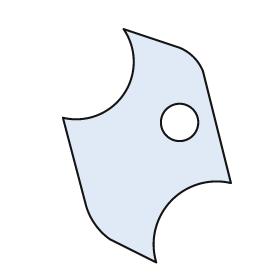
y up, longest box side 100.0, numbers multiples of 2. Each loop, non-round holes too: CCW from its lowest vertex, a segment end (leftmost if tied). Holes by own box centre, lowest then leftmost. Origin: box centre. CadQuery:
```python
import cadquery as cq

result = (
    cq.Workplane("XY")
    .moveTo(4.0, -50.0)
    .threePointArc((10.0, -24.0), (36.0, -16.0))
    .lineTo(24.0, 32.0)
    .threePointArc((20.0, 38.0), (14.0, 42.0))
    .lineTo(-10.0, 50.0)
    .threePointArc((-10.0, 22.0), (-36.0, 12.0))
    .lineTo(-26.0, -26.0)
    .threePointArc((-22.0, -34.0), (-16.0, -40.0))
    .close()
    .moveTo(14.0, 10.0)
    .circle(8.0)
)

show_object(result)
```